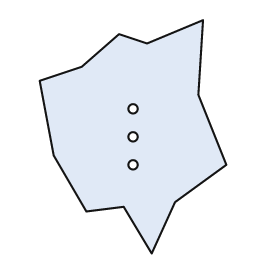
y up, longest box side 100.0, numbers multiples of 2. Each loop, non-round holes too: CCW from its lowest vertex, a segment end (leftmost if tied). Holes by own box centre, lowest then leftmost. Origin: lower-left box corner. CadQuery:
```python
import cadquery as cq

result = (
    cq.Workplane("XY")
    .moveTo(48.0, 0.0)
    .lineTo(58.0, 22.0)
    .lineTo(80.0, 38.0)
    .lineTo(68.0, 68.0)
    .lineTo(70.0, 100.0)
    .lineTo(46.0, 90.0)
    .lineTo(34.0, 94.0)
    .lineTo(18.0, 80.0)
    .lineTo(0.0, 74.0)
    .lineTo(6.0, 42.0)
    .lineTo(20.0, 18.0)
    .lineTo(36.0, 20.0)
    .close()
    .moveTo(40.0, 38.0)
    .circle(2.0)
    .moveTo(40.0, 50.0)
    .circle(2.0)
    .moveTo(40.0, 62.0)
    .circle(2.0)
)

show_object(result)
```